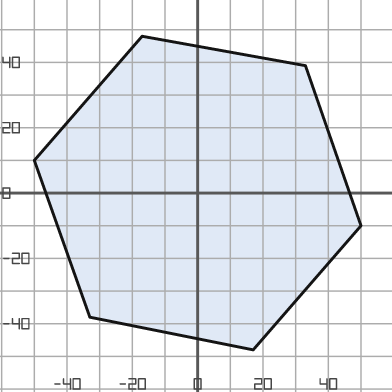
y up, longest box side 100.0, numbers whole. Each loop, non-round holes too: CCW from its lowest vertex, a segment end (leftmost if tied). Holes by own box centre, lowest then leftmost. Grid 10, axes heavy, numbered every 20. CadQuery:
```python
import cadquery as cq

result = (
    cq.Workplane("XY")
    .moveTo(17.0, -48.0)
    .lineTo(50.0, -10.0)
    .lineTo(33.0, 39.0)
    .lineTo(-17.0, 48.0)
    .lineTo(-50.0, 10.0)
    .lineTo(-33.0, -38.0)
    .close()
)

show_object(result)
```